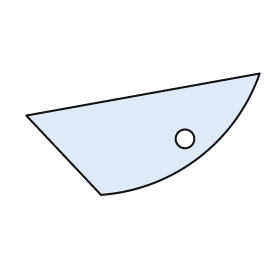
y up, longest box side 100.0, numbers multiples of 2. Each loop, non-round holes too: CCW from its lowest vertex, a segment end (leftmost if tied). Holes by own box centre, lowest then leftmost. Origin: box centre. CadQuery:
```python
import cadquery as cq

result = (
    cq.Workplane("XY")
    .moveTo(-18.0, -26.0)
    .threePointArc((24.0, -10.0), (50.0, 26.0))
    .lineTo(-50.0, 8.0)
    .close()
    .moveTo(18.0, -2.0)
    .circle(4.0)
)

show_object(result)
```